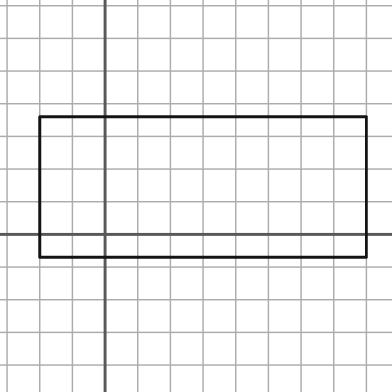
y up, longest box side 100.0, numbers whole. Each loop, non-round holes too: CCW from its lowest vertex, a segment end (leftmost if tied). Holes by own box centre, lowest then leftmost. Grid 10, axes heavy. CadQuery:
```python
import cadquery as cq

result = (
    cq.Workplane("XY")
    .moveTo(-20.0, -7.0)
    .lineTo(80.0, -7.0)
    .lineTo(80.0, 36.0)
    .lineTo(-20.0, 36.0)
    .close()
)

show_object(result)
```